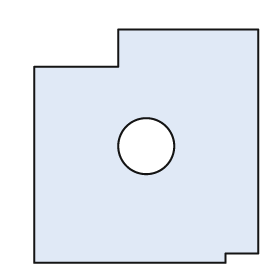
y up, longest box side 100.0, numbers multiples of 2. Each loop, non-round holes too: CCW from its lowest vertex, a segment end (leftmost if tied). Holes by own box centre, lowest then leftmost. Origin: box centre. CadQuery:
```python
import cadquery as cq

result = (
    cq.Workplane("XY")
    .moveTo(-48.0, -50.0)
    .lineTo(34.0, -50.0)
    .lineTo(34.0, -46.0)
    .lineTo(48.0, -46.0)
    .lineTo(48.0, 50.0)
    .lineTo(-12.0, 50.0)
    .lineTo(-12.0, 34.0)
    .lineTo(-48.0, 34.0)
    .close()
    .moveTo(0.0, 0.0)
    .circle(12.0)
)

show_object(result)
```